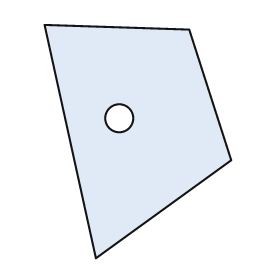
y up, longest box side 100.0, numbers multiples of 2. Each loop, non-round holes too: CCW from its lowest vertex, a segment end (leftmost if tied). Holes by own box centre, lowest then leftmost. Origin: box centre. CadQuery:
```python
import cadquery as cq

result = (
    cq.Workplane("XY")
    .moveTo(-18.0, -50.0)
    .lineTo(40.0, -8.0)
    .lineTo(22.0, 48.0)
    .lineTo(-40.0, 50.0)
    .close()
    .moveTo(-8.0, 10.0)
    .circle(6.0)
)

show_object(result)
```